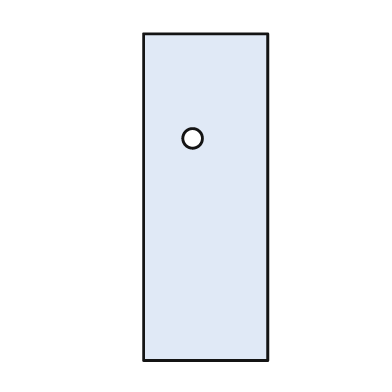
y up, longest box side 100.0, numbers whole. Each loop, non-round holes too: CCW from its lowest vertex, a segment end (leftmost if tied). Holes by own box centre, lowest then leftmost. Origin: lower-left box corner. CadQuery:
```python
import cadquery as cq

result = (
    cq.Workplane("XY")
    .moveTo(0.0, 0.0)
    .lineTo(38.0, 0.0)
    .lineTo(38.0, 100.0)
    .lineTo(0.0, 100.0)
    .close()
    .moveTo(15.0, 68.0)
    .circle(3.0)
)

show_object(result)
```